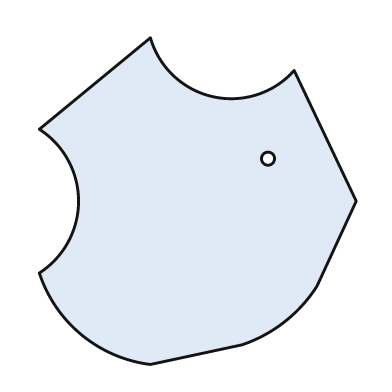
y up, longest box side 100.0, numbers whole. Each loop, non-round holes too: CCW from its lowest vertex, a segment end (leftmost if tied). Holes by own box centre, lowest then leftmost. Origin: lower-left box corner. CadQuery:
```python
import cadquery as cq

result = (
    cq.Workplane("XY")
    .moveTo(34.0, 0.0)
    .lineTo(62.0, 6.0)
    .threePointArc((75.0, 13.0), (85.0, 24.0))
    .lineTo(97.0, 50.0)
    .lineTo(78.0, 90.0)
    .threePointArc((53.0, 82.0), (34.0, 100.0))
    .lineTo(0.0, 72.0)
    .threePointArc((12.0, 50.0), (0.0, 28.0))
    .threePointArc((13.0, 9.0), (34.0, 0.0))
    .close()
    .moveTo(70.0, 63.0)
    .circle(2.0)
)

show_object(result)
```